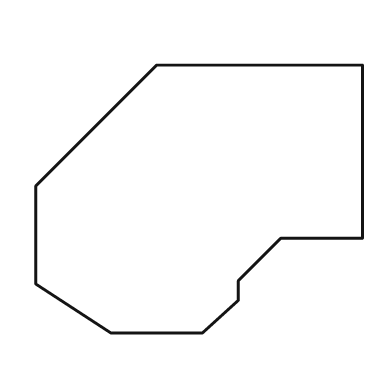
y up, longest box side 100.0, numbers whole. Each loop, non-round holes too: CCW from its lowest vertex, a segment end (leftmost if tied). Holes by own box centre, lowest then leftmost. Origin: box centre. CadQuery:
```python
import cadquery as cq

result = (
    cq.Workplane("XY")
    .moveTo(-27.0, -41.0)
    .lineTo(1.0, -41.0)
    .lineTo(12.0, -31.0)
    .lineTo(12.0, -25.0)
    .lineTo(25.0, -12.0)
    .lineTo(50.0, -12.0)
    .lineTo(50.0, 41.0)
    .lineTo(-13.0, 41.0)
    .lineTo(-50.0, 4.0)
    .lineTo(-50.0, -26.0)
    .close()
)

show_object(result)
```